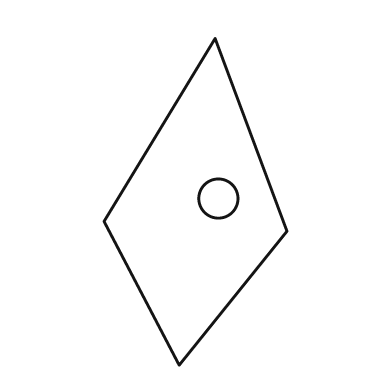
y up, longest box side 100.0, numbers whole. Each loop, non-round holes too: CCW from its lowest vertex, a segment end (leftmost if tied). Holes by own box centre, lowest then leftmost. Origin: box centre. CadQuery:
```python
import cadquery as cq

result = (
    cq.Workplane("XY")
    .moveTo(-5.0, -50.0)
    .lineTo(28.0, -9.0)
    .lineTo(6.0, 50.0)
    .lineTo(-28.0, -6.0)
    .close()
    .moveTo(7.0, 1.0)
    .circle(6.0)
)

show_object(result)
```